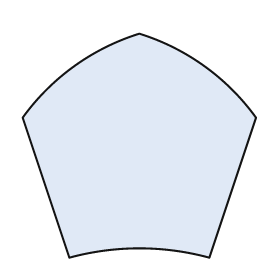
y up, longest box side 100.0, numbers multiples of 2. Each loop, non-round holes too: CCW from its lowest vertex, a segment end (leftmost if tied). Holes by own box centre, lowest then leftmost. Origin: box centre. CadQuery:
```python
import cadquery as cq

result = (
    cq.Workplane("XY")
    .moveTo(-30.0, -48.0)
    .threePointArc((0.0, -44.0), (30.0, -48.0))
    .lineTo(50.0, 12.0)
    .threePointArc((28.0, 34.0), (0.0, 48.0))
    .threePointArc((-28.0, 34.0), (-50.0, 12.0))
    .close()
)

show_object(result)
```